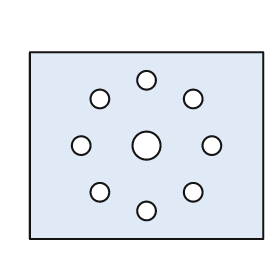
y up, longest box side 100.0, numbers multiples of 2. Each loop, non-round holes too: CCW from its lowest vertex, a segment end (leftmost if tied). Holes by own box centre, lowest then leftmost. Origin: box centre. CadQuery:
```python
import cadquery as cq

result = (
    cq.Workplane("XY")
    .moveTo(-50.0, -40.0)
    .lineTo(50.0, -40.0)
    .lineTo(50.0, 40.0)
    .lineTo(-50.0, 40.0)
    .close()
    .moveTo(0.0, -28.0)
    .circle(4.0)
    .moveTo(-20.0, -20.0)
    .circle(4.0)
    .moveTo(20.0, -20.0)
    .circle(4.0)
    .moveTo(-28.0, 0.0)
    .circle(4.0)
    .moveTo(0.0, 0.0)
    .circle(6.0)
    .moveTo(28.0, 0.0)
    .circle(4.0)
    .moveTo(-20.0, 20.0)
    .circle(4.0)
    .moveTo(20.0, 20.0)
    .circle(4.0)
    .moveTo(0.0, 28.0)
    .circle(4.0)
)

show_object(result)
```